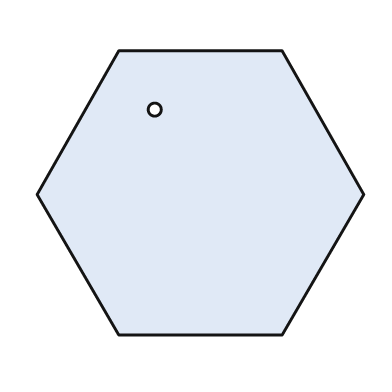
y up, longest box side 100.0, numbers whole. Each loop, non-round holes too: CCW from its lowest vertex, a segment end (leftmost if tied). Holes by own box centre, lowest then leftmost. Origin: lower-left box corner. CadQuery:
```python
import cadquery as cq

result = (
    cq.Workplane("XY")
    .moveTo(25.0, 0.0)
    .lineTo(75.0, 0.0)
    .lineTo(100.0, 43.0)
    .lineTo(75.0, 87.0)
    .lineTo(25.0, 87.0)
    .lineTo(0.0, 43.0)
    .close()
    .moveTo(36.0, 69.0)
    .circle(2.0)
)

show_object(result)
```